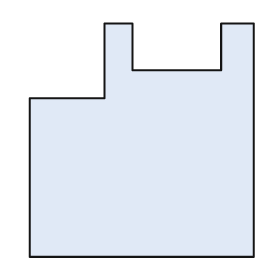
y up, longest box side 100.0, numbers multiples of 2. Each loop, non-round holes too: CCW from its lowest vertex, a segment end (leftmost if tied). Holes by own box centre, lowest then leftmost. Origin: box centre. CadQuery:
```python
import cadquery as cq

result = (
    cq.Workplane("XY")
    .moveTo(-48.0, -50.0)
    .lineTo(48.0, -50.0)
    .lineTo(48.0, 50.0)
    .lineTo(34.0, 50.0)
    .lineTo(34.0, 30.0)
    .lineTo(-4.0, 30.0)
    .lineTo(-4.0, 50.0)
    .lineTo(-16.0, 50.0)
    .lineTo(-16.0, 18.0)
    .lineTo(-48.0, 18.0)
    .close()
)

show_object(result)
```